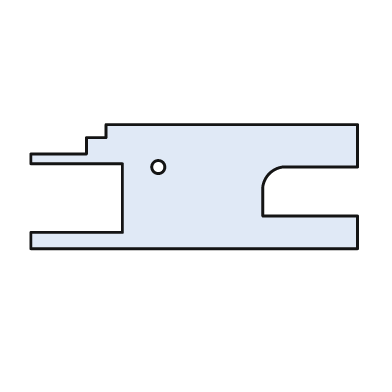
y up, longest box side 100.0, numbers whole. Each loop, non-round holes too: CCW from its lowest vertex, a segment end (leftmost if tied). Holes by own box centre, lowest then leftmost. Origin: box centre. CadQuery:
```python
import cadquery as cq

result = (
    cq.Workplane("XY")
    .moveTo(-50.0, -19.0)
    .lineTo(50.0, -19.0)
    .lineTo(50.0, -9.0)
    .lineTo(21.0, -9.0)
    .lineTo(21.0, 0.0)
    .threePointArc((23.0, 4.0), (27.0, 6.0))
    .lineTo(50.0, 6.0)
    .lineTo(50.0, 19.0)
    .lineTo(-27.0, 19.0)
    .lineTo(-27.0, 15.0)
    .lineTo(-33.0, 15.0)
    .lineTo(-33.0, 10.0)
    .lineTo(-50.0, 10.0)
    .lineTo(-50.0, 7.0)
    .lineTo(-22.0, 7.0)
    .lineTo(-22.0, -14.0)
    .lineTo(-50.0, -14.0)
    .close()
    .moveTo(-11.0, 6.0)
    .circle(2.0)
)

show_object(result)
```